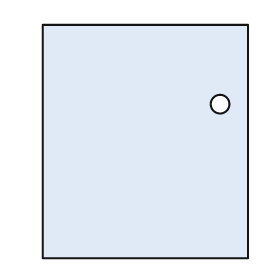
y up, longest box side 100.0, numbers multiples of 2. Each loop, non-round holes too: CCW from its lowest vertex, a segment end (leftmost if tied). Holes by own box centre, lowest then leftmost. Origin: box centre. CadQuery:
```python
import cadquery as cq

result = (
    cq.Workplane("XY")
    .moveTo(-44.0, -50.0)
    .lineTo(44.0, -50.0)
    .lineTo(44.0, 50.0)
    .lineTo(-44.0, 50.0)
    .close()
    .moveTo(32.0, 16.0)
    .circle(4.0)
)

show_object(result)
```